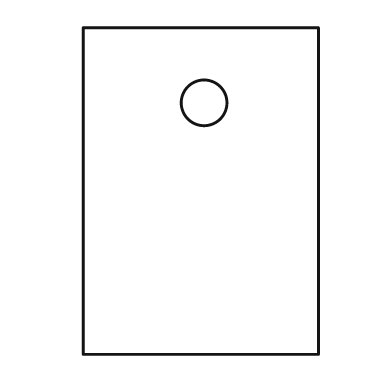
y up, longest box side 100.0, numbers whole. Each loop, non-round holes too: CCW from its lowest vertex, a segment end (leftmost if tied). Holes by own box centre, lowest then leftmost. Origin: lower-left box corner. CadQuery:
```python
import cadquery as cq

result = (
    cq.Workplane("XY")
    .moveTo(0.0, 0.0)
    .lineTo(72.0, 0.0)
    .lineTo(72.0, 100.0)
    .lineTo(0.0, 100.0)
    .close()
    .moveTo(37.0, 77.0)
    .circle(7.0)
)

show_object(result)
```